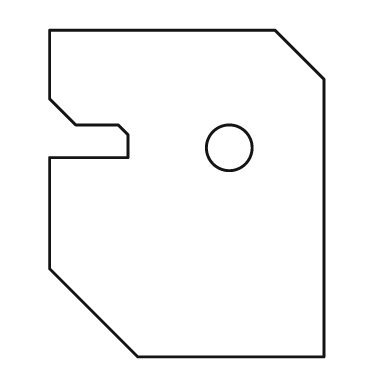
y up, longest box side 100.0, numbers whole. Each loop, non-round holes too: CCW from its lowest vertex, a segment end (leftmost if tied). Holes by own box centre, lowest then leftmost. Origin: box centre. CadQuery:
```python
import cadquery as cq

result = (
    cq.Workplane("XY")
    .moveTo(-15.0, -50.0)
    .lineTo(42.0, -50.0)
    .lineTo(42.0, 35.0)
    .lineTo(27.0, 50.0)
    .lineTo(-42.0, 50.0)
    .lineTo(-42.0, 29.0)
    .lineTo(-34.0, 21.0)
    .lineTo(-21.0, 21.0)
    .lineTo(-18.0, 18.0)
    .lineTo(-18.0, 11.0)
    .lineTo(-42.0, 11.0)
    .lineTo(-42.0, -23.0)
    .close()
    .moveTo(13.0, 14.0)
    .circle(7.0)
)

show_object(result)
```